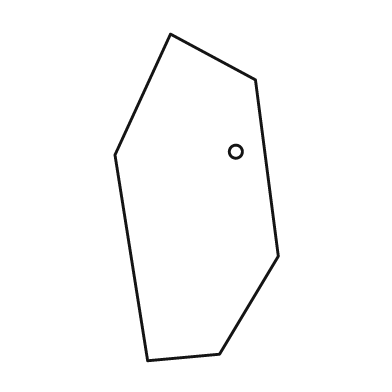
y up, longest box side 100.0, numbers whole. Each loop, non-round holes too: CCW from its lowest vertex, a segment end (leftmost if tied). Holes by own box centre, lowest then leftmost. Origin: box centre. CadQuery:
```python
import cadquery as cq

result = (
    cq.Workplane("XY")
    .moveTo(-15.0, -50.0)
    .lineTo(7.0, -48.0)
    .lineTo(25.0, -18.0)
    .lineTo(18.0, 36.0)
    .lineTo(-8.0, 50.0)
    .lineTo(-25.0, 13.0)
    .close()
    .moveTo(12.0, 14.0)
    .circle(2.0)
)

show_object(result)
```